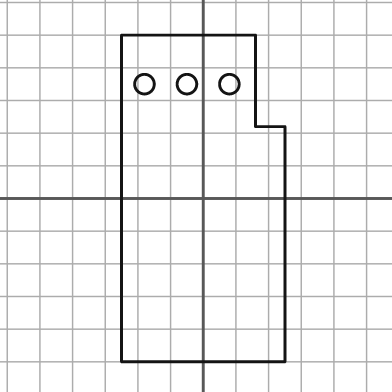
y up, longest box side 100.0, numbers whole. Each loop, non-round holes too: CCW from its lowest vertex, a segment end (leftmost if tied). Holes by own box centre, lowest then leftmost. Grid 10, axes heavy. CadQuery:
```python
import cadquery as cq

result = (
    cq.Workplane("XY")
    .moveTo(-25.0, -50.0)
    .lineTo(25.0, -50.0)
    .lineTo(25.0, 22.0)
    .lineTo(16.0, 22.0)
    .lineTo(16.0, 50.0)
    .lineTo(-25.0, 50.0)
    .close()
    .moveTo(-18.0, 35.0)
    .circle(3.0)
    .moveTo(-5.0, 35.0)
    .circle(3.0)
    .moveTo(8.0, 35.0)
    .circle(3.0)
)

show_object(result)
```